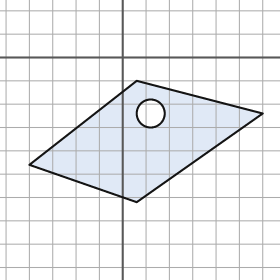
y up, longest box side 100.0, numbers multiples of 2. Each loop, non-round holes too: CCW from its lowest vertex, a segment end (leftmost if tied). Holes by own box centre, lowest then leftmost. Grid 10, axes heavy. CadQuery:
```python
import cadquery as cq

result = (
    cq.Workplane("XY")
    .moveTo(6.0, -62.0)
    .lineTo(60.0, -24.0)
    .lineTo(6.0, -10.0)
    .lineTo(-40.0, -46.0)
    .close()
    .moveTo(12.0, -24.0)
    .circle(6.0)
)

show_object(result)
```